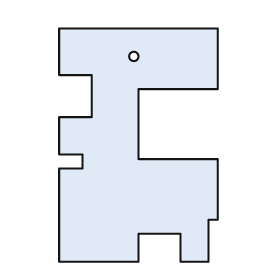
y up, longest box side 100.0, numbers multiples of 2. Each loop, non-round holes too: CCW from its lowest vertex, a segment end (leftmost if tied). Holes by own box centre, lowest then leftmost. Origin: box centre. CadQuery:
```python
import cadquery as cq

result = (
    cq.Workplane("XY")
    .moveTo(-34.0, -50.0)
    .lineTo(0.0, -50.0)
    .lineTo(0.0, -38.0)
    .lineTo(18.0, -38.0)
    .lineTo(18.0, -50.0)
    .lineTo(30.0, -50.0)
    .lineTo(30.0, -32.0)
    .lineTo(34.0, -32.0)
    .lineTo(34.0, -6.0)
    .lineTo(0.0, -6.0)
    .lineTo(0.0, 24.0)
    .lineTo(34.0, 24.0)
    .lineTo(34.0, 50.0)
    .lineTo(-34.0, 50.0)
    .lineTo(-34.0, 30.0)
    .lineTo(-20.0, 30.0)
    .lineTo(-20.0, 12.0)
    .lineTo(-34.0, 12.0)
    .lineTo(-34.0, -4.0)
    .lineTo(-24.0, -4.0)
    .lineTo(-24.0, -10.0)
    .lineTo(-34.0, -10.0)
    .close()
    .moveTo(-2.0, 38.0)
    .circle(2.0)
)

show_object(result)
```